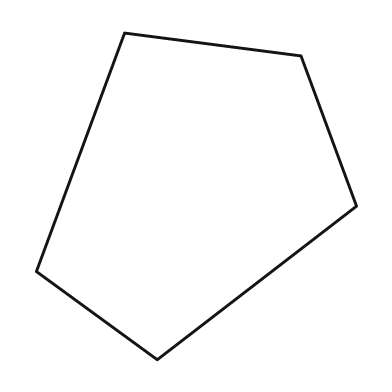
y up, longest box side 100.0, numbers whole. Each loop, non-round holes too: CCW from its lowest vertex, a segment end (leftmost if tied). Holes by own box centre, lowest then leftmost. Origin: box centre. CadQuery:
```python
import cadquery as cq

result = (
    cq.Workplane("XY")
    .moveTo(-12.0, -50.0)
    .lineTo(49.0, -3.0)
    .lineTo(32.0, 43.0)
    .lineTo(-22.0, 50.0)
    .lineTo(-49.0, -23.0)
    .close()
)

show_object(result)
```